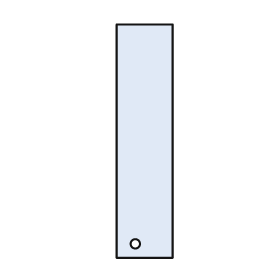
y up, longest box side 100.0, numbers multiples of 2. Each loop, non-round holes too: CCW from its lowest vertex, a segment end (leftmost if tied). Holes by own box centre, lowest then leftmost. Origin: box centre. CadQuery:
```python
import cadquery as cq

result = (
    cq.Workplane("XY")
    .moveTo(-12.0, -50.0)
    .lineTo(12.0, -50.0)
    .lineTo(12.0, 50.0)
    .lineTo(-12.0, 50.0)
    .close()
    .moveTo(-4.0, -44.0)
    .circle(2.0)
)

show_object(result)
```